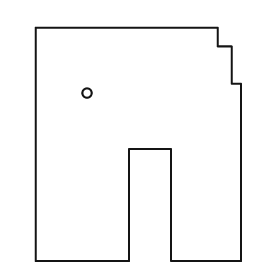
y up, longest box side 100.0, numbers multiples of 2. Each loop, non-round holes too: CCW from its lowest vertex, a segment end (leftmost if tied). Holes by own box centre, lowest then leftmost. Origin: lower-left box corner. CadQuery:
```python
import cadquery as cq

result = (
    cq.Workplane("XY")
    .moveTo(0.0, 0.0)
    .lineTo(40.0, 0.0)
    .lineTo(40.0, 48.0)
    .lineTo(58.0, 48.0)
    .lineTo(58.0, 0.0)
    .lineTo(88.0, 0.0)
    .lineTo(88.0, 76.0)
    .lineTo(84.0, 76.0)
    .lineTo(84.0, 92.0)
    .lineTo(78.0, 92.0)
    .lineTo(78.0, 100.0)
    .lineTo(0.0, 100.0)
    .close()
    .moveTo(22.0, 72.0)
    .circle(2.0)
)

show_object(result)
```